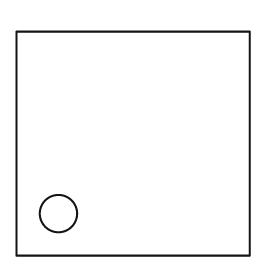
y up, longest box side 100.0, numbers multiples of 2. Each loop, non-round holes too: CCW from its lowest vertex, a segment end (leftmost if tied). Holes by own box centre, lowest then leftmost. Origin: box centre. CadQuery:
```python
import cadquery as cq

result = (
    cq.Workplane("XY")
    .moveTo(-50.0, -48.0)
    .lineTo(50.0, -48.0)
    .lineTo(50.0, 48.0)
    .lineTo(-50.0, 48.0)
    .close()
    .moveTo(-32.0, -30.0)
    .circle(8.0)
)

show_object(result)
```